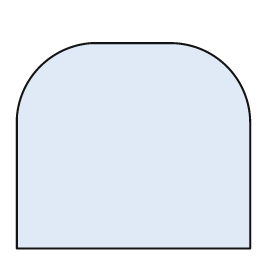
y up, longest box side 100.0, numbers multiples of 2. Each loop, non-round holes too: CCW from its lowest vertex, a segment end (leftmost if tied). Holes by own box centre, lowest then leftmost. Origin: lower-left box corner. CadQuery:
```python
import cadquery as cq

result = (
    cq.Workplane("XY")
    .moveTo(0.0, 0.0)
    .lineTo(100.0, 0.0)
    .lineTo(100.0, 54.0)
    .threePointArc((90.0, 78.0), (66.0, 88.0))
    .lineTo(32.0, 88.0)
    .threePointArc((10.0, 78.0), (0.0, 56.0))
    .close()
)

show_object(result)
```